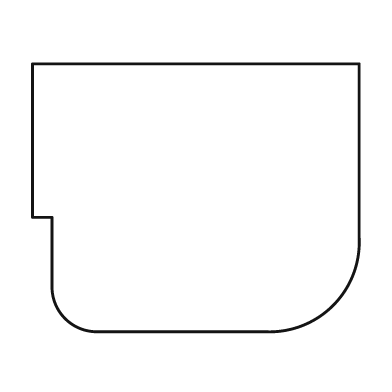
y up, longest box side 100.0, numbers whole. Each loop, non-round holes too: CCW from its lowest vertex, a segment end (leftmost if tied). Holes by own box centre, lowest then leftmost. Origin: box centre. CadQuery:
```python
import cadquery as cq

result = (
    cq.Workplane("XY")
    .moveTo(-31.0, -41.0)
    .lineTo(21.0, -41.0)
    .threePointArc((42.0, -33.0), (50.0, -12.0))
    .lineTo(50.0, 41.0)
    .lineTo(-50.0, 41.0)
    .lineTo(-50.0, -6.0)
    .lineTo(-44.0, -6.0)
    .lineTo(-44.0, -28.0)
    .threePointArc((-40.0, -37.0), (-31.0, -41.0))
    .close()
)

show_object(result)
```